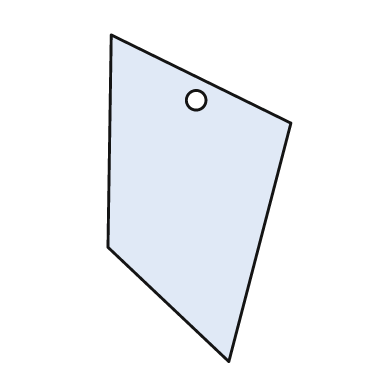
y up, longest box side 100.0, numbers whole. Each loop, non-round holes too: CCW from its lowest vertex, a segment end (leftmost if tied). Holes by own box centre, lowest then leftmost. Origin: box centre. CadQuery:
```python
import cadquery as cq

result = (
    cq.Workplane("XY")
    .moveTo(9.0, -50.0)
    .lineTo(28.0, 23.0)
    .lineTo(-27.0, 50.0)
    .lineTo(-28.0, -15.0)
    .close()
    .moveTo(-1.0, 30.0)
    .circle(3.0)
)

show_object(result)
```